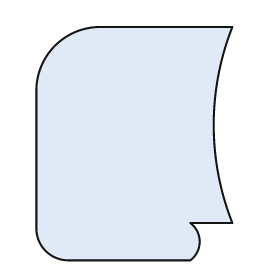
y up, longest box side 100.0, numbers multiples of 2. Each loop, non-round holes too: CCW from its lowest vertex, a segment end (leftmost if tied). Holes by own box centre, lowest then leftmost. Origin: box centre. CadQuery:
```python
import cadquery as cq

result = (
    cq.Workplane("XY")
    .moveTo(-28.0, -50.0)
    .lineTo(24.0, -50.0)
    .threePointArc((28.0, -42.0), (24.0, -34.0))
    .lineTo(42.0, -34.0)
    .threePointArc((34.0, 8.0), (42.0, 50.0))
    .lineTo(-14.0, 50.0)
    .threePointArc((-34.0, 42.0), (-42.0, 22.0))
    .lineTo(-42.0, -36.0)
    .threePointArc((-38.0, -46.0), (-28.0, -50.0))
    .close()
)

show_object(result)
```